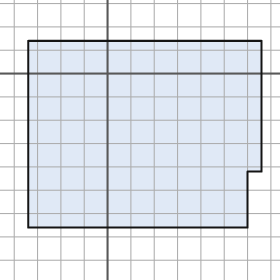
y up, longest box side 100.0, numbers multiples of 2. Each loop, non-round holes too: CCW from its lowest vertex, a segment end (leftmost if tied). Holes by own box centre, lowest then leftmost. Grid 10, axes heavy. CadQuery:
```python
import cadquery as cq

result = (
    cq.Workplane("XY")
    .moveTo(-34.0, -66.0)
    .lineTo(60.0, -66.0)
    .lineTo(60.0, -42.0)
    .lineTo(66.0, -42.0)
    .lineTo(66.0, 14.0)
    .lineTo(-34.0, 14.0)
    .close()
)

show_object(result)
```